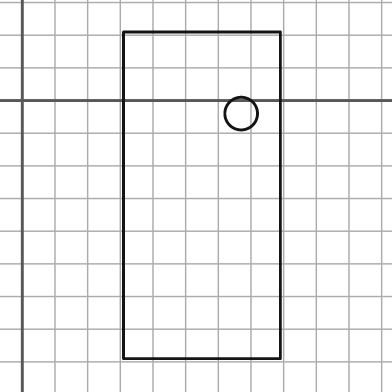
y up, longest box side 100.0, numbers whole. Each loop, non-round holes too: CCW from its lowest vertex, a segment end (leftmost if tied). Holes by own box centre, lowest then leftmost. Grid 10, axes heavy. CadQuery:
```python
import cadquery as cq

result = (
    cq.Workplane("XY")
    .moveTo(31.0, -79.0)
    .lineTo(79.0, -79.0)
    .lineTo(79.0, 21.0)
    .lineTo(31.0, 21.0)
    .close()
    .moveTo(67.0, -4.0)
    .circle(5.0)
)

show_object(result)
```